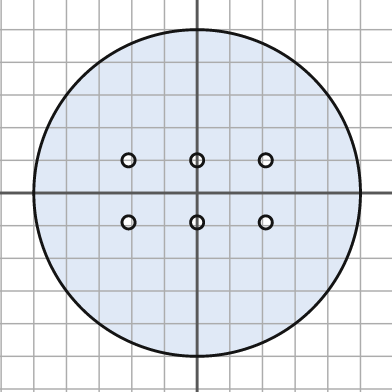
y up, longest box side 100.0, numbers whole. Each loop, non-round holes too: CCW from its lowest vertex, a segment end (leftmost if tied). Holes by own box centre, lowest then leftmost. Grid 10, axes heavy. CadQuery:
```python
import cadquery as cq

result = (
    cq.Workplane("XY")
    .moveTo(0.0, 0.0)
    .circle(50.0)
    .moveTo(-21.0, -9.0)
    .circle(2.0)
    .moveTo(0.0, -9.0)
    .circle(2.0)
    .moveTo(21.0, -9.0)
    .circle(2.0)
    .moveTo(-21.0, 10.0)
    .circle(2.0)
    .moveTo(0.0, 10.0)
    .circle(2.0)
    .moveTo(21.0, 10.0)
    .circle(2.0)
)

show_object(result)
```